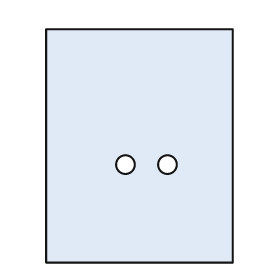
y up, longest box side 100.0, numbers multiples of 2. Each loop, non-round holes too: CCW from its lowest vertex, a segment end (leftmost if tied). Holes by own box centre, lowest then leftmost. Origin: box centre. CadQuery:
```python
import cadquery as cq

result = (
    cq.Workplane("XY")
    .moveTo(-40.0, -50.0)
    .lineTo(40.0, -50.0)
    .lineTo(40.0, 50.0)
    .lineTo(-40.0, 50.0)
    .close()
    .moveTo(-6.0, -8.0)
    .circle(4.0)
    .moveTo(12.0, -8.0)
    .circle(4.0)
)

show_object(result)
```